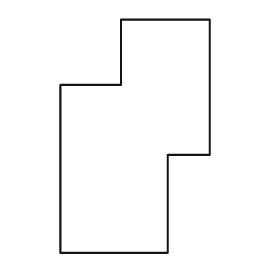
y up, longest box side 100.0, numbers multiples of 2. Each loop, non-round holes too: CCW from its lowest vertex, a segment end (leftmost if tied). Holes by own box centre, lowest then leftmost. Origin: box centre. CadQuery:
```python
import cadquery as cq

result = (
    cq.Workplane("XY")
    .moveTo(-32.0, -50.0)
    .lineTo(14.0, -50.0)
    .lineTo(14.0, -8.0)
    .lineTo(32.0, -8.0)
    .lineTo(32.0, 50.0)
    .lineTo(-6.0, 50.0)
    .lineTo(-6.0, 22.0)
    .lineTo(-32.0, 22.0)
    .close()
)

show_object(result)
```